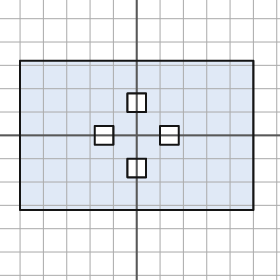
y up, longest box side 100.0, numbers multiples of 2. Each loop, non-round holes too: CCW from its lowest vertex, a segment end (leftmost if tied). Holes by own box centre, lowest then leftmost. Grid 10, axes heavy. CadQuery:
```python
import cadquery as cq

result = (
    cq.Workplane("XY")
    .moveTo(-50.0, -32.0)
    .lineTo(50.0, -32.0)
    .lineTo(50.0, 32.0)
    .lineTo(-50.0, 32.0)
    .close()
    .moveTo(-4.0, -18.0)
    .lineTo(4.0, -18.0)
    .lineTo(4.0, -10.0)
    .lineTo(-4.0, -10.0)
    .close()
    .moveTo(-18.0, -4.0)
    .lineTo(-10.0, -4.0)
    .lineTo(-10.0, 4.0)
    .lineTo(-18.0, 4.0)
    .close()
    .moveTo(10.0, -4.0)
    .lineTo(18.0, -4.0)
    .lineTo(18.0, 4.0)
    .lineTo(10.0, 4.0)
    .close()
    .moveTo(-4.0, 10.0)
    .lineTo(4.0, 10.0)
    .lineTo(4.0, 18.0)
    .lineTo(-4.0, 18.0)
    .close()
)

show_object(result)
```